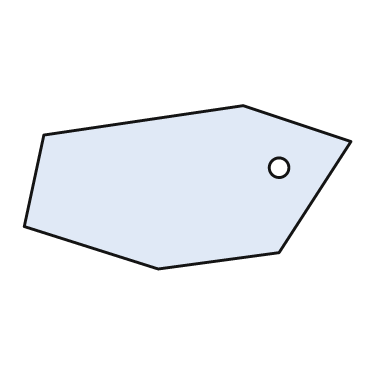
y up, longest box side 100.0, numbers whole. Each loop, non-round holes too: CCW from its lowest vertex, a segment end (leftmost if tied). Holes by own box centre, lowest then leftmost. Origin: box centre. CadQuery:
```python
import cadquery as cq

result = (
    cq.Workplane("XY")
    .moveTo(-9.0, -25.0)
    .lineTo(28.0, -20.0)
    .lineTo(50.0, 14.0)
    .lineTo(17.0, 25.0)
    .lineTo(-44.0, 16.0)
    .lineTo(-50.0, -12.0)
    .close()
    .moveTo(28.0, 6.0)
    .circle(3.0)
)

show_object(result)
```